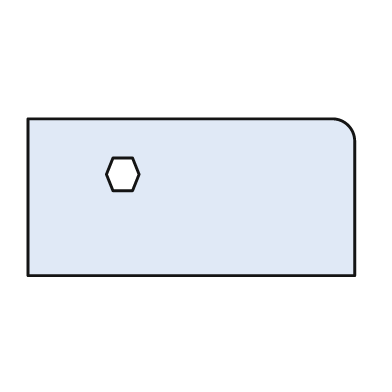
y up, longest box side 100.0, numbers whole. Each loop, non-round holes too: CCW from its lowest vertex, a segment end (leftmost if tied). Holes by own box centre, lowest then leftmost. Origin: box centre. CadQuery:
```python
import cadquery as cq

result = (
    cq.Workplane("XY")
    .moveTo(-50.0, -24.0)
    .lineTo(50.0, -24.0)
    .lineTo(50.0, 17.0)
    .threePointArc((48.0, 22.0), (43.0, 24.0))
    .lineTo(-50.0, 24.0)
    .close()
    .moveTo(-24.0, 2.0)
    .lineTo(-18.0, 2.0)
    .lineTo(-16.0, 7.0)
    .lineTo(-18.0, 12.0)
    .lineTo(-24.0, 12.0)
    .lineTo(-26.0, 7.0)
    .close()
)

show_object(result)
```